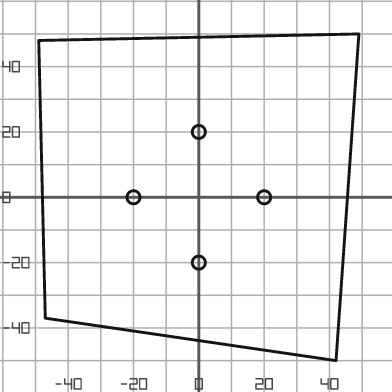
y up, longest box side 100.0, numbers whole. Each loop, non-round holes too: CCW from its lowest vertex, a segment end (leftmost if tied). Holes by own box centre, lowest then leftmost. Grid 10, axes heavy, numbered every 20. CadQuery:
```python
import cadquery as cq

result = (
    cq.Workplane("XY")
    .moveTo(42.0, -50.0)
    .lineTo(49.0, 50.0)
    .lineTo(-49.0, 48.0)
    .lineTo(-47.0, -37.0)
    .close()
    .moveTo(0.0, -20.0)
    .circle(2.0)
    .moveTo(-20.0, 0.0)
    .circle(2.0)
    .moveTo(20.0, 0.0)
    .circle(2.0)
    .moveTo(0.0, 20.0)
    .circle(2.0)
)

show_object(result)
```